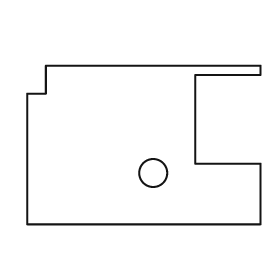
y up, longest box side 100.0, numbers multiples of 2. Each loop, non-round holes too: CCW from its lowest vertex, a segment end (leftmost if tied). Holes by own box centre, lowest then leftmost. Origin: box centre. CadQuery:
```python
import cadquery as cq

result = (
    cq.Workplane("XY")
    .moveTo(-50.0, -34.0)
    .lineTo(50.0, -34.0)
    .lineTo(50.0, -8.0)
    .lineTo(22.0, -8.0)
    .lineTo(22.0, 30.0)
    .lineTo(50.0, 30.0)
    .lineTo(50.0, 34.0)
    .lineTo(-42.0, 34.0)
    .lineTo(-42.0, 22.0)
    .lineTo(-50.0, 22.0)
    .close()
    .moveTo(4.0, -12.0)
    .circle(6.0)
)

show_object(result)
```